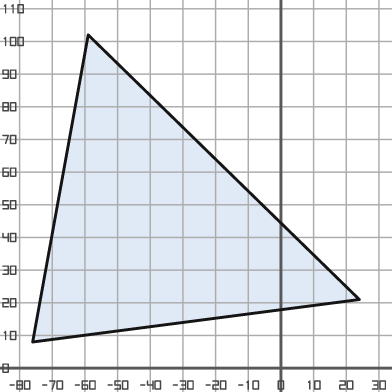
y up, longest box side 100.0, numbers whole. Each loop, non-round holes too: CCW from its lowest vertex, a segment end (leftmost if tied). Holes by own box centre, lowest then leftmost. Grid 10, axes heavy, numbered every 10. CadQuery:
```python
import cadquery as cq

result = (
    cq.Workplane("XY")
    .moveTo(-76.0, 8.0)
    .lineTo(24.0, 21.0)
    .lineTo(-59.0, 102.0)
    .close()
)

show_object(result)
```